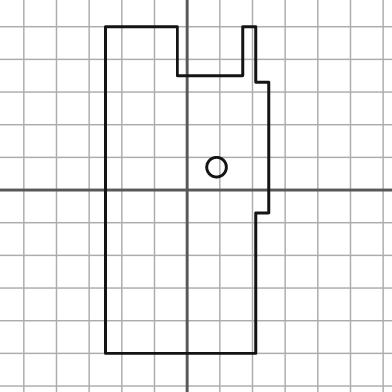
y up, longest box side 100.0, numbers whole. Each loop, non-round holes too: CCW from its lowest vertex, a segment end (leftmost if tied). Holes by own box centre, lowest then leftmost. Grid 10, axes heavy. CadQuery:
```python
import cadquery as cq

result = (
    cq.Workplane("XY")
    .moveTo(-25.0, -50.0)
    .lineTo(21.0, -50.0)
    .lineTo(21.0, -7.0)
    .lineTo(25.0, -7.0)
    .lineTo(25.0, 33.0)
    .lineTo(21.0, 33.0)
    .lineTo(21.0, 50.0)
    .lineTo(17.0, 50.0)
    .lineTo(17.0, 35.0)
    .lineTo(-3.0, 35.0)
    .lineTo(-3.0, 50.0)
    .lineTo(-25.0, 50.0)
    .close()
    .moveTo(9.0, 7.0)
    .circle(3.0)
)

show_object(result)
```